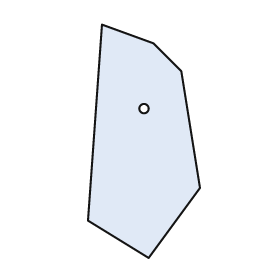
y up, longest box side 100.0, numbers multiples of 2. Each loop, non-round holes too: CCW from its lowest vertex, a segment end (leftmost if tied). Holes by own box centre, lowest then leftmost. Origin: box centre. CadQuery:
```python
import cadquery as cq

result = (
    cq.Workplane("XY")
    .moveTo(2.0, -50.0)
    .lineTo(24.0, -20.0)
    .lineTo(16.0, 30.0)
    .lineTo(4.0, 42.0)
    .lineTo(-18.0, 50.0)
    .lineTo(-24.0, -34.0)
    .close()
    .moveTo(0.0, 14.0)
    .circle(2.0)
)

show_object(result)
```